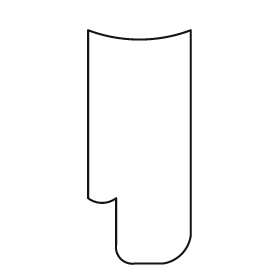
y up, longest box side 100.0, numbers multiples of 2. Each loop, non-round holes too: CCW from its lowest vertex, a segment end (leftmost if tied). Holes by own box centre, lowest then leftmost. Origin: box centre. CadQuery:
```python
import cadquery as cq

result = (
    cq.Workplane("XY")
    .moveTo(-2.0, -50.0)
    .lineTo(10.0, -50.0)
    .threePointArc((18.0, -46.0), (22.0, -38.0))
    .lineTo(22.0, 50.0)
    .threePointArc((0.0, 46.0), (-22.0, 50.0))
    .lineTo(-22.0, -22.0)
    .threePointArc((-16.0, -24.0), (-10.0, -22.0))
    .lineTo(-10.0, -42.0)
    .threePointArc((-8.0, -48.0), (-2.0, -50.0))
    .close()
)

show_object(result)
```